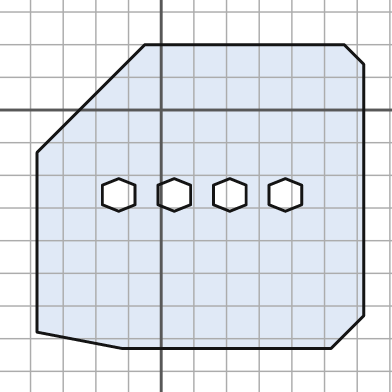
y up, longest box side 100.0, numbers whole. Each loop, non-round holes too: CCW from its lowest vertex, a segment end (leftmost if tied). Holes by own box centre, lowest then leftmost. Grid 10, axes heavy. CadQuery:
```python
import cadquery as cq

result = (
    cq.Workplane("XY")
    .moveTo(-12.0, -73.0)
    .lineTo(52.0, -73.0)
    .lineTo(62.0, -63.0)
    .lineTo(62.0, 14.0)
    .lineTo(56.0, 20.0)
    .lineTo(-5.0, 20.0)
    .lineTo(-38.0, -13.0)
    .lineTo(-38.0, -68.0)
    .close()
    .moveTo(-13.0, -31.0)
    .lineTo(-8.0, -29.0)
    .lineTo(-8.0, -23.0)
    .lineTo(-13.0, -21.0)
    .lineTo(-18.0, -23.0)
    .lineTo(-18.0, -29.0)
    .close()
    .moveTo(4.0, -31.0)
    .lineTo(9.0, -29.0)
    .lineTo(9.0, -23.0)
    .lineTo(4.0, -21.0)
    .lineTo(-1.0, -23.0)
    .lineTo(-1.0, -29.0)
    .close()
    .moveTo(21.0, -31.0)
    .lineTo(26.0, -29.0)
    .lineTo(26.0, -23.0)
    .lineTo(21.0, -21.0)
    .lineTo(16.0, -23.0)
    .lineTo(16.0, -29.0)
    .close()
    .moveTo(38.0, -31.0)
    .lineTo(43.0, -29.0)
    .lineTo(43.0, -23.0)
    .lineTo(38.0, -21.0)
    .lineTo(33.0, -23.0)
    .lineTo(33.0, -29.0)
    .close()
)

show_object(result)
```